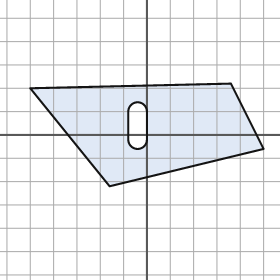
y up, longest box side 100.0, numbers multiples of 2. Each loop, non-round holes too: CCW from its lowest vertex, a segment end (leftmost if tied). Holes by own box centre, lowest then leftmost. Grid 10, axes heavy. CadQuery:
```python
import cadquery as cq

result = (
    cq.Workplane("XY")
    .moveTo(-16.0, -22.0)
    .lineTo(50.0, -6.0)
    .lineTo(36.0, 22.0)
    .lineTo(-50.0, 20.0)
    .close()
    .moveTo(-8.0, -2.0)
    .threePointArc((-4.0, -6.0), (0.0, -2.0))
    .lineTo(0.0, 10.0)
    .threePointArc((-4.0, 14.0), (-8.0, 10.0))
    .close()
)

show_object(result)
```